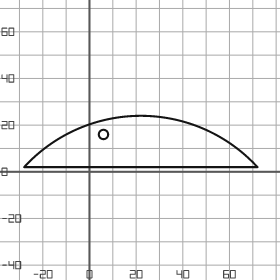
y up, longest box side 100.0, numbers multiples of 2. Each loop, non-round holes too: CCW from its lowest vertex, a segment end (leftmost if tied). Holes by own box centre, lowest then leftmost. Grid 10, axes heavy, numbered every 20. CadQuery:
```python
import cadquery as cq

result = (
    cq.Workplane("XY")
    .moveTo(-28.0, 2.0)
    .lineTo(72.0, 2.0)
    .threePointArc((22.0, 24.0), (-28.0, 2.0))
    .close()
    .moveTo(6.0, 16.0)
    .circle(2.0)
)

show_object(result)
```